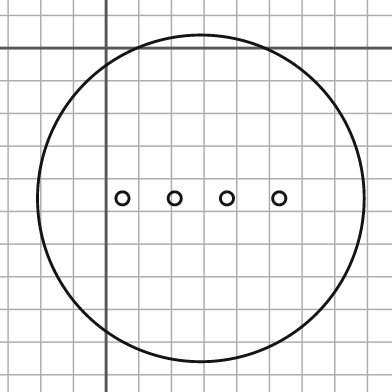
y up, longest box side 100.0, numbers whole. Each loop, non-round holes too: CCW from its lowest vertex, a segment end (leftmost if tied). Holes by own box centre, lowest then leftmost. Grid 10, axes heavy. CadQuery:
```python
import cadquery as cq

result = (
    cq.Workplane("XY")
    .moveTo(29.0, -46.0)
    .circle(50.0)
    .moveTo(5.0, -46.0)
    .circle(2.0)
    .moveTo(21.0, -46.0)
    .circle(2.0)
    .moveTo(37.0, -46.0)
    .circle(2.0)
    .moveTo(53.0, -46.0)
    .circle(2.0)
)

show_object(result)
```